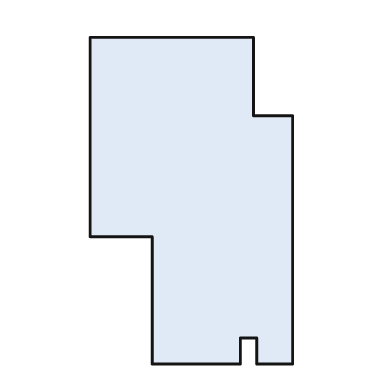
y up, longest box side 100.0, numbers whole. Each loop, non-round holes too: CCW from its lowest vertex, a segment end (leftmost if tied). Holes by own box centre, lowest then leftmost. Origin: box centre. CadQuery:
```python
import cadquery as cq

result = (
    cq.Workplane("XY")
    .moveTo(-12.0, -50.0)
    .lineTo(15.0, -50.0)
    .lineTo(15.0, -42.0)
    .lineTo(20.0, -42.0)
    .lineTo(20.0, -50.0)
    .lineTo(31.0, -50.0)
    .lineTo(31.0, 26.0)
    .lineTo(19.0, 26.0)
    .lineTo(19.0, 50.0)
    .lineTo(-31.0, 50.0)
    .lineTo(-31.0, -11.0)
    .lineTo(-12.0, -11.0)
    .close()
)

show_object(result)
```